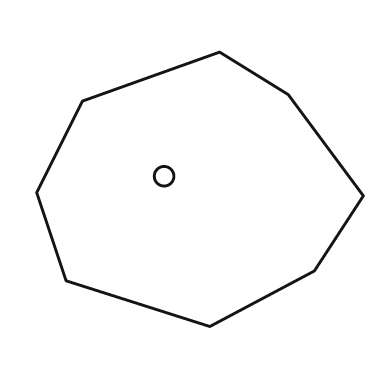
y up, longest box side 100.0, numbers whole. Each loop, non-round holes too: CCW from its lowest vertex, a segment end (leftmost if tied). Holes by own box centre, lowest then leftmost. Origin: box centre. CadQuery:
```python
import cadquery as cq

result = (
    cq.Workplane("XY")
    .moveTo(3.0, -42.0)
    .lineTo(35.0, -25.0)
    .lineTo(50.0, -2.0)
    .lineTo(27.0, 29.0)
    .lineTo(6.0, 42.0)
    .lineTo(-36.0, 27.0)
    .lineTo(-50.0, -1.0)
    .lineTo(-41.0, -28.0)
    .close()
    .moveTo(-11.0, 4.0)
    .circle(3.0)
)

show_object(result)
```